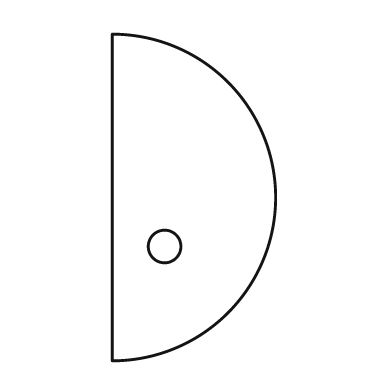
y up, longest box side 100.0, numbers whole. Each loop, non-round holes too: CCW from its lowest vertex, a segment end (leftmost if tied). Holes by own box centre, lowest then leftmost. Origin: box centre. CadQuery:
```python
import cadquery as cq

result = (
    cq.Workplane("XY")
    .moveTo(-25.0, -50.0)
    .threePointArc((25.0, 0.0), (-25.0, 50.0))
    .close()
    .moveTo(-9.0, -15.0)
    .circle(5.0)
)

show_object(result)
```